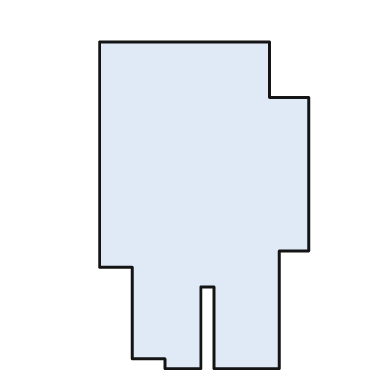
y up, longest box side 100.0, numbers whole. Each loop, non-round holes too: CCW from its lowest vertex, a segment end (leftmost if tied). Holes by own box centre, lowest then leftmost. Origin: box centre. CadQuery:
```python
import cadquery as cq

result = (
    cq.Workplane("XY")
    .moveTo(-12.0, -50.0)
    .lineTo(-1.0, -50.0)
    .lineTo(-1.0, -25.0)
    .lineTo(3.0, -25.0)
    .lineTo(3.0, -50.0)
    .lineTo(23.0, -50.0)
    .lineTo(23.0, -14.0)
    .lineTo(32.0, -14.0)
    .lineTo(32.0, 33.0)
    .lineTo(20.0, 33.0)
    .lineTo(20.0, 50.0)
    .lineTo(-32.0, 50.0)
    .lineTo(-32.0, -19.0)
    .lineTo(-22.0, -19.0)
    .lineTo(-22.0, -47.0)
    .lineTo(-12.0, -47.0)
    .close()
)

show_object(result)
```